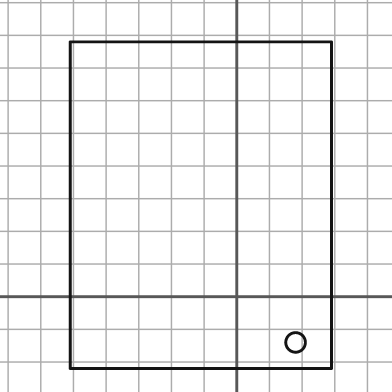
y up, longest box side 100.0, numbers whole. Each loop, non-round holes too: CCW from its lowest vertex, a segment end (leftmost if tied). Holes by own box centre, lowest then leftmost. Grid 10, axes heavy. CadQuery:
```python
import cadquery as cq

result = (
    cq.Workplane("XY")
    .moveTo(-51.0, -22.0)
    .lineTo(29.0, -22.0)
    .lineTo(29.0, 78.0)
    .lineTo(-51.0, 78.0)
    .close()
    .moveTo(18.0, -14.0)
    .circle(3.0)
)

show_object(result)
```